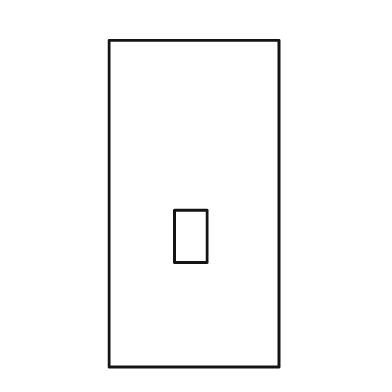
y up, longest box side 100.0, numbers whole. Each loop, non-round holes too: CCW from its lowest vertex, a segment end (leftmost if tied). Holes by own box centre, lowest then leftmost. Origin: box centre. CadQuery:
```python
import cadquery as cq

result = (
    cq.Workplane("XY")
    .moveTo(-26.0, -50.0)
    .lineTo(26.0, -50.0)
    .lineTo(26.0, 50.0)
    .lineTo(-26.0, 50.0)
    .close()
    .moveTo(-6.0, -18.0)
    .lineTo(4.0, -18.0)
    .lineTo(4.0, -2.0)
    .lineTo(-6.0, -2.0)
    .close()
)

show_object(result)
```